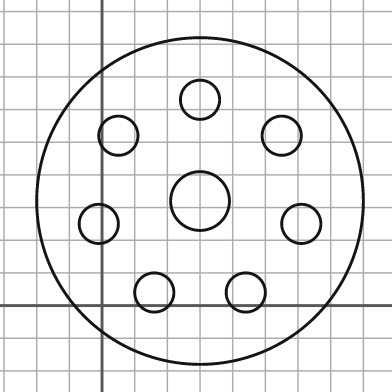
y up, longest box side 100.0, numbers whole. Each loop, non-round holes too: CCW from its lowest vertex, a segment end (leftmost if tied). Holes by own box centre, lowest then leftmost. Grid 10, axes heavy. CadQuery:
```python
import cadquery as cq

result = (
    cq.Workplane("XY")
    .moveTo(30.0, 32.0)
    .circle(50.0)
    .moveTo(16.0, 4.0)
    .circle(6.0)
    .moveTo(44.0, 4.0)
    .circle(6.0)
    .moveTo(-1.0, 25.0)
    .circle(6.0)
    .moveTo(61.0, 25.0)
    .circle(6.0)
    .moveTo(30.0, 32.0)
    .circle(9.0)
    .moveTo(5.0, 52.0)
    .circle(6.0)
    .moveTo(55.0, 52.0)
    .circle(6.0)
    .moveTo(30.0, 63.0)
    .circle(6.0)
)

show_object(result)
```